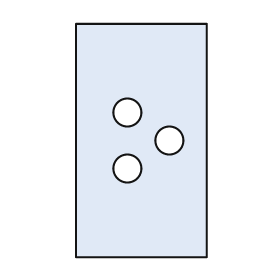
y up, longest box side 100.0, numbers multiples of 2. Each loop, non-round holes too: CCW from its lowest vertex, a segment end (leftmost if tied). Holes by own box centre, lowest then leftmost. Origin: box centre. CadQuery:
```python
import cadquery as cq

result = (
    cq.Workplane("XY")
    .moveTo(-28.0, -50.0)
    .lineTo(28.0, -50.0)
    .lineTo(28.0, 50.0)
    .lineTo(-28.0, 50.0)
    .close()
    .moveTo(-6.0, -12.0)
    .circle(6.0)
    .moveTo(12.0, 0.0)
    .circle(6.0)
    .moveTo(-6.0, 12.0)
    .circle(6.0)
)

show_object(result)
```